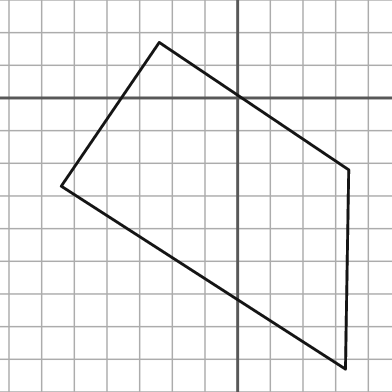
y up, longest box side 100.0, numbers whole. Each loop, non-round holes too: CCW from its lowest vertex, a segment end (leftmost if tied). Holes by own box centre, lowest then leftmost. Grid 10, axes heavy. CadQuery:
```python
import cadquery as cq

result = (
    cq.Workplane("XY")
    .moveTo(33.0, -83.0)
    .lineTo(34.0, -22.0)
    .lineTo(-24.0, 17.0)
    .lineTo(-54.0, -27.0)
    .close()
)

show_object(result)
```